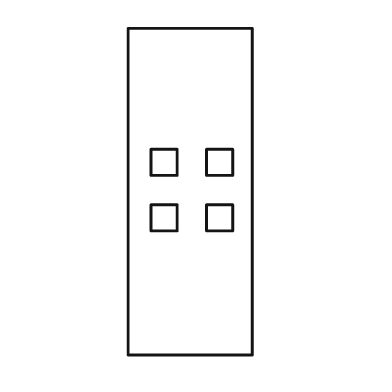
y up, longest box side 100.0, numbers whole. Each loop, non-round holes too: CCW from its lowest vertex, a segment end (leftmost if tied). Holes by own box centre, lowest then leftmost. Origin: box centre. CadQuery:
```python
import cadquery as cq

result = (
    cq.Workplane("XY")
    .moveTo(-19.0, -50.0)
    .lineTo(19.0, -50.0)
    .lineTo(19.0, 50.0)
    .lineTo(-19.0, 50.0)
    .close()
    .moveTo(-12.0, -12.0)
    .lineTo(-4.0, -12.0)
    .lineTo(-4.0, -4.0)
    .lineTo(-12.0, -4.0)
    .close()
    .moveTo(5.0, -12.0)
    .lineTo(13.0, -12.0)
    .lineTo(13.0, -4.0)
    .lineTo(5.0, -4.0)
    .close()
    .moveTo(-12.0, 5.0)
    .lineTo(-4.0, 5.0)
    .lineTo(-4.0, 13.0)
    .lineTo(-12.0, 13.0)
    .close()
    .moveTo(5.0, 5.0)
    .lineTo(13.0, 5.0)
    .lineTo(13.0, 13.0)
    .lineTo(5.0, 13.0)
    .close()
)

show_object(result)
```